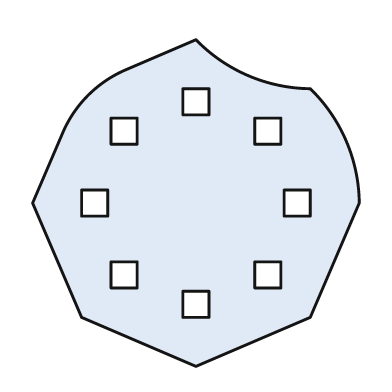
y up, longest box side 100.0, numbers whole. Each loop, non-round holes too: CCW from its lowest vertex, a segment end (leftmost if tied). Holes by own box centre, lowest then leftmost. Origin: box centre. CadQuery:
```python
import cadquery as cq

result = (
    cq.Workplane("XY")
    .moveTo(0.0, -50.0)
    .lineTo(35.0, -35.0)
    .lineTo(50.0, 0.0)
    .threePointArc((46.0, 19.0), (35.0, 35.0))
    .threePointArc((16.0, 39.0), (0.0, 50.0))
    .lineTo(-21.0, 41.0)
    .threePointArc((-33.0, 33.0), (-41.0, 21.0))
    .lineTo(-50.0, 0.0)
    .lineTo(-35.0, -35.0)
    .close()
    .moveTo(-4.0, -35.0)
    .lineTo(4.0, -35.0)
    .lineTo(4.0, -27.0)
    .lineTo(-4.0, -27.0)
    .close()
    .moveTo(-26.0, -26.0)
    .lineTo(-18.0, -26.0)
    .lineTo(-18.0, -18.0)
    .lineTo(-26.0, -18.0)
    .close()
    .moveTo(18.0, -26.0)
    .lineTo(26.0, -26.0)
    .lineTo(26.0, -18.0)
    .lineTo(18.0, -18.0)
    .close()
    .moveTo(-35.0, -4.0)
    .lineTo(-27.0, -4.0)
    .lineTo(-27.0, 4.0)
    .lineTo(-35.0, 4.0)
    .close()
    .moveTo(27.0, -4.0)
    .lineTo(35.0, -4.0)
    .lineTo(35.0, 4.0)
    .lineTo(27.0, 4.0)
    .close()
    .moveTo(-26.0, 18.0)
    .lineTo(-18.0, 18.0)
    .lineTo(-18.0, 26.0)
    .lineTo(-26.0, 26.0)
    .close()
    .moveTo(18.0, 18.0)
    .lineTo(26.0, 18.0)
    .lineTo(26.0, 26.0)
    .lineTo(18.0, 26.0)
    .close()
    .moveTo(-4.0, 27.0)
    .lineTo(4.0, 27.0)
    .lineTo(4.0, 35.0)
    .lineTo(-4.0, 35.0)
    .close()
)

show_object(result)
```